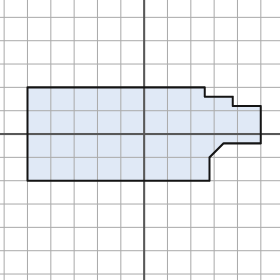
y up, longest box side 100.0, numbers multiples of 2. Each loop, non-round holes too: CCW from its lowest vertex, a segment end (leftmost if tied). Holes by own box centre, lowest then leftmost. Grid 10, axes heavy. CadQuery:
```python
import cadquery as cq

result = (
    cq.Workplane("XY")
    .moveTo(-50.0, -20.0)
    .lineTo(28.0, -20.0)
    .lineTo(28.0, -10.0)
    .lineTo(34.0, -4.0)
    .lineTo(50.0, -4.0)
    .lineTo(50.0, 12.0)
    .lineTo(38.0, 12.0)
    .lineTo(38.0, 16.0)
    .lineTo(26.0, 16.0)
    .lineTo(26.0, 20.0)
    .lineTo(-50.0, 20.0)
    .close()
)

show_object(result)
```